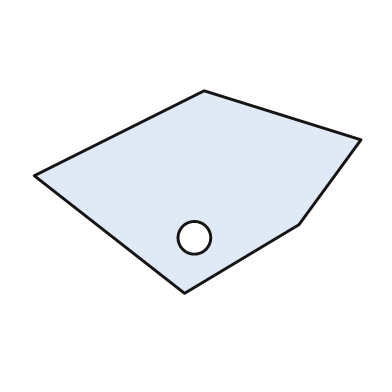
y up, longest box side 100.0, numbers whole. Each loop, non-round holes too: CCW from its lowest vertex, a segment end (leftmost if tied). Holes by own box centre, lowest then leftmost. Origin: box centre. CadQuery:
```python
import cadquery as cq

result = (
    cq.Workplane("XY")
    .moveTo(-4.0, -31.0)
    .lineTo(31.0, -10.0)
    .lineTo(50.0, 16.0)
    .lineTo(2.0, 31.0)
    .lineTo(-50.0, 5.0)
    .close()
    .moveTo(-1.0, -14.0)
    .circle(5.0)
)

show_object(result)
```